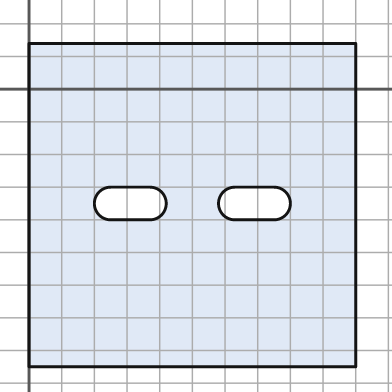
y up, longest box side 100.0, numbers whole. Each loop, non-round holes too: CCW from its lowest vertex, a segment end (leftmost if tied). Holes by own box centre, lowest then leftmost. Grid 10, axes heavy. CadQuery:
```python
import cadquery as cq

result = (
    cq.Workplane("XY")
    .moveTo(0.0, -85.0)
    .lineTo(100.0, -85.0)
    .lineTo(100.0, 14.0)
    .lineTo(0.0, 14.0)
    .close()
    .moveTo(25.0, -40.0)
    .lineTo(37.0, -40.0)
    .threePointArc((42.0, -35.0), (37.0, -30.0))
    .lineTo(25.0, -30.0)
    .threePointArc((20.0, -35.0), (25.0, -40.0))
    .close()
    .moveTo(63.0, -40.0)
    .lineTo(75.0, -40.0)
    .threePointArc((80.0, -35.0), (75.0, -30.0))
    .lineTo(63.0, -30.0)
    .threePointArc((58.0, -35.0), (63.0, -40.0))
    .close()
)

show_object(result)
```